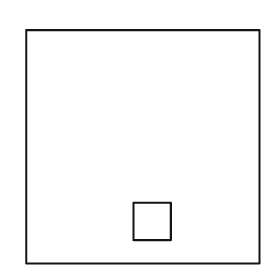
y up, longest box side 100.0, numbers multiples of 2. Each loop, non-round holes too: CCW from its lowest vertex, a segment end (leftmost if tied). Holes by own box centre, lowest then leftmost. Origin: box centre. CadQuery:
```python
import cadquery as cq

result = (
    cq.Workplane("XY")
    .moveTo(-50.0, -50.0)
    .lineTo(50.0, -50.0)
    .lineTo(50.0, 50.0)
    .lineTo(-50.0, 50.0)
    .close()
    .moveTo(-4.0, -40.0)
    .lineTo(12.0, -40.0)
    .lineTo(12.0, -24.0)
    .lineTo(-4.0, -24.0)
    .close()
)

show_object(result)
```